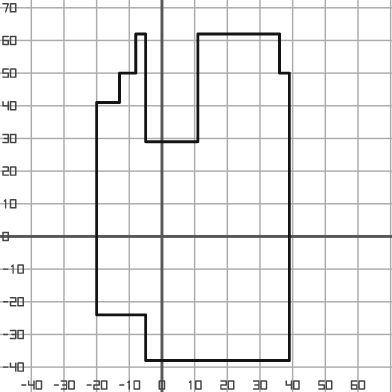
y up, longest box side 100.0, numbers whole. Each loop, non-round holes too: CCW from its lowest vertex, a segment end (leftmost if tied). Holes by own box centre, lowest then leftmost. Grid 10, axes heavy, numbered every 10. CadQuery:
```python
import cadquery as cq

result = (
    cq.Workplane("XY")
    .moveTo(-5.0, -38.0)
    .lineTo(39.0, -38.0)
    .lineTo(39.0, 50.0)
    .lineTo(36.0, 50.0)
    .lineTo(36.0, 62.0)
    .lineTo(11.0, 62.0)
    .lineTo(11.0, 29.0)
    .lineTo(-5.0, 29.0)
    .lineTo(-5.0, 62.0)
    .lineTo(-8.0, 62.0)
    .lineTo(-8.0, 50.0)
    .lineTo(-13.0, 50.0)
    .lineTo(-13.0, 41.0)
    .lineTo(-20.0, 41.0)
    .lineTo(-20.0, -24.0)
    .lineTo(-5.0, -24.0)
    .close()
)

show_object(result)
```